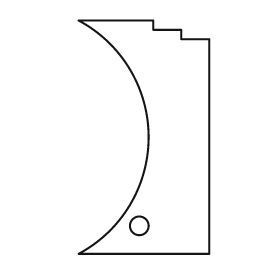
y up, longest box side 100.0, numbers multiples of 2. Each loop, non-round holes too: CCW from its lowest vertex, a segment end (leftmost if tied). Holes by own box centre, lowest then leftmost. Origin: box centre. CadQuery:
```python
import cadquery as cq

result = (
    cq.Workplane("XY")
    .moveTo(-28.0, -50.0)
    .lineTo(28.0, -50.0)
    .lineTo(28.0, 42.0)
    .lineTo(16.0, 42.0)
    .lineTo(16.0, 46.0)
    .lineTo(4.0, 46.0)
    .lineTo(4.0, 50.0)
    .lineTo(-28.0, 50.0)
    .threePointArc((2.0, 0.0), (-28.0, -50.0))
    .close()
    .moveTo(-2.0, -38.0)
    .circle(4.0)
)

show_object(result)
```